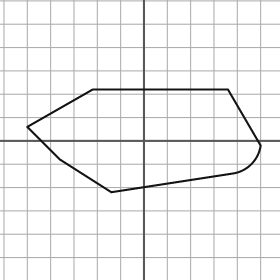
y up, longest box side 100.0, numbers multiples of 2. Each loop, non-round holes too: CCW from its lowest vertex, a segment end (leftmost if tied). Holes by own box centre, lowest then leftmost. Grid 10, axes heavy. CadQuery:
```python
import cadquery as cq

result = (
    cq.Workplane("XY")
    .moveTo(-14.0, -22.0)
    .lineTo(38.0, -14.0)
    .threePointArc((46.0, -10.0), (50.0, -2.0))
    .lineTo(36.0, 22.0)
    .lineTo(-22.0, 22.0)
    .lineTo(-50.0, 6.0)
    .lineTo(-36.0, -8.0)
    .close()
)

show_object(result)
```